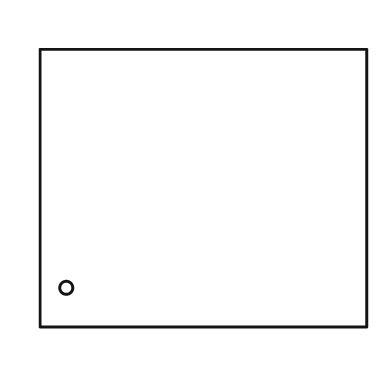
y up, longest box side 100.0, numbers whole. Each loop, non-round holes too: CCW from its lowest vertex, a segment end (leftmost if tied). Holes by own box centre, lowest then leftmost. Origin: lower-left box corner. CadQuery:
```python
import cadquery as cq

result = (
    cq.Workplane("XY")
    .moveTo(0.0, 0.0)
    .lineTo(100.0, 0.0)
    .lineTo(100.0, 85.0)
    .lineTo(0.0, 85.0)
    .close()
    .moveTo(8.0, 12.0)
    .circle(2.0)
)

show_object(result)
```